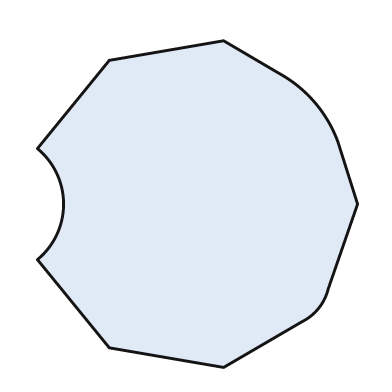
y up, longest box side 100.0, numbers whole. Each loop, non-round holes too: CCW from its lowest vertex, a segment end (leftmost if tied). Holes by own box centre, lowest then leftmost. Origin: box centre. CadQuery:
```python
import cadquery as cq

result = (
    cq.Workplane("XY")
    .moveTo(8.0, -50.0)
    .lineTo(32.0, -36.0)
    .threePointArc((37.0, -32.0), (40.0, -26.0))
    .lineTo(49.0, 0.0)
    .lineTo(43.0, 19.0)
    .threePointArc((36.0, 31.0), (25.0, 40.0))
    .lineTo(8.0, 50.0)
    .lineTo(-27.0, 44.0)
    .lineTo(-49.0, 17.0)
    .threePointArc((-41.0, 0.0), (-49.0, -17.0))
    .lineTo(-27.0, -44.0)
    .close()
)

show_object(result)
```